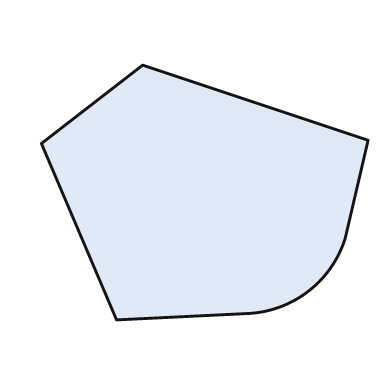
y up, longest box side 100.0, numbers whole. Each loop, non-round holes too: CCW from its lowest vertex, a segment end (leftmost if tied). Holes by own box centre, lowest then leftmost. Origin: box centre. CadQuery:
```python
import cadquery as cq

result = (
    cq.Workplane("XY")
    .moveTo(-27.0, -39.0)
    .lineTo(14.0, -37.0)
    .threePointArc((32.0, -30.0), (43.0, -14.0))
    .lineTo(50.0, 16.0)
    .lineTo(-19.0, 39.0)
    .lineTo(-50.0, 15.0)
    .close()
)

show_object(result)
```